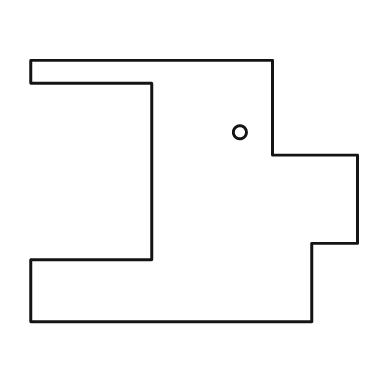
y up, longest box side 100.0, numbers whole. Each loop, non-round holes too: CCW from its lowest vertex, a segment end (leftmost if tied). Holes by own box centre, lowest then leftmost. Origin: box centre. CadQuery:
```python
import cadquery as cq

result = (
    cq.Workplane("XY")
    .moveTo(-50.0, -40.0)
    .lineTo(36.0, -40.0)
    .lineTo(36.0, -16.0)
    .lineTo(50.0, -16.0)
    .lineTo(50.0, 11.0)
    .lineTo(24.0, 11.0)
    .lineTo(24.0, 40.0)
    .lineTo(-50.0, 40.0)
    .lineTo(-50.0, 33.0)
    .lineTo(-13.0, 33.0)
    .lineTo(-13.0, -21.0)
    .lineTo(-50.0, -21.0)
    .close()
    .moveTo(14.0, 18.0)
    .circle(2.0)
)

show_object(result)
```